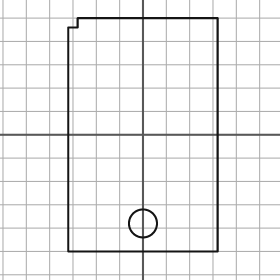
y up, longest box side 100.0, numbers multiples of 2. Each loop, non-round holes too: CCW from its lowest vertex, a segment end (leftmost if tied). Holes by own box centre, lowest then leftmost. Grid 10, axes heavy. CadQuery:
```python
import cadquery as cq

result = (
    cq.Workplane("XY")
    .moveTo(-32.0, -50.0)
    .lineTo(32.0, -50.0)
    .lineTo(32.0, 50.0)
    .lineTo(-28.0, 50.0)
    .lineTo(-28.0, 46.0)
    .lineTo(-32.0, 46.0)
    .close()
    .moveTo(0.0, -38.0)
    .circle(6.0)
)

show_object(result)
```